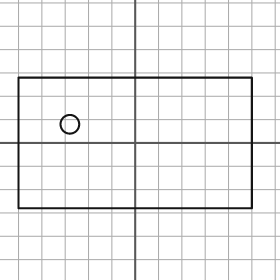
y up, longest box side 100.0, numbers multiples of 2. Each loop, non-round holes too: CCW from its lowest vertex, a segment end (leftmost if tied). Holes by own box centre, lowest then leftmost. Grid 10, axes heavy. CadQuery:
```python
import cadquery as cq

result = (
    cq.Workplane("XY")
    .moveTo(-50.0, -28.0)
    .lineTo(50.0, -28.0)
    .lineTo(50.0, 28.0)
    .lineTo(-50.0, 28.0)
    .close()
    .moveTo(-28.0, 8.0)
    .circle(4.0)
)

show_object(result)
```